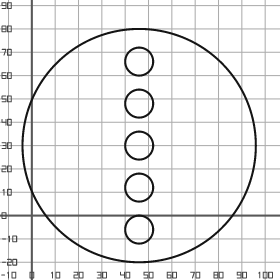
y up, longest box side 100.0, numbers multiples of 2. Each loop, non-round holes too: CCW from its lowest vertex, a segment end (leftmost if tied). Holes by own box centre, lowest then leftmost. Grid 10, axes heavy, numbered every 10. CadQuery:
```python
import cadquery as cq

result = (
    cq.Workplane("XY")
    .moveTo(46.0, 30.0)
    .circle(50.0)
    .moveTo(46.0, -6.0)
    .circle(6.0)
    .moveTo(46.0, 12.0)
    .circle(6.0)
    .moveTo(46.0, 30.0)
    .circle(6.0)
    .moveTo(46.0, 48.0)
    .circle(6.0)
    .moveTo(46.0, 66.0)
    .circle(6.0)
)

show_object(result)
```